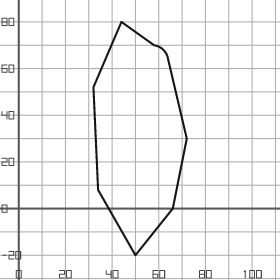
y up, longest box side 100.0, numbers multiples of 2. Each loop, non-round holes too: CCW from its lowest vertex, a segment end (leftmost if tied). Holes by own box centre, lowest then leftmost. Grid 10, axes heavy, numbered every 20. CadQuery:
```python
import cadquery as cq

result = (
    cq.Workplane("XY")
    .moveTo(50.0, -20.0)
    .lineTo(66.0, 0.0)
    .lineTo(72.0, 30.0)
    .lineTo(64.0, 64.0)
    .threePointArc((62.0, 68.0), (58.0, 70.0))
    .lineTo(44.0, 80.0)
    .lineTo(32.0, 52.0)
    .lineTo(34.0, 8.0)
    .close()
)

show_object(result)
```